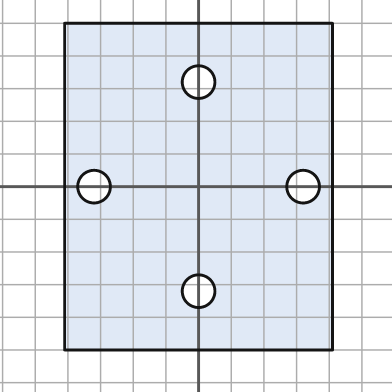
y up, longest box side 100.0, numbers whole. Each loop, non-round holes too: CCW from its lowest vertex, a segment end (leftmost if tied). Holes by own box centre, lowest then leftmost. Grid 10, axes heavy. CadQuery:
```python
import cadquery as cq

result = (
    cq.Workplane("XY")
    .moveTo(-41.0, -50.0)
    .lineTo(41.0, -50.0)
    .lineTo(41.0, 50.0)
    .lineTo(-41.0, 50.0)
    .close()
    .moveTo(0.0, -32.0)
    .circle(5.0)
    .moveTo(-32.0, 0.0)
    .circle(5.0)
    .moveTo(32.0, 0.0)
    .circle(5.0)
    .moveTo(0.0, 32.0)
    .circle(5.0)
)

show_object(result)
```